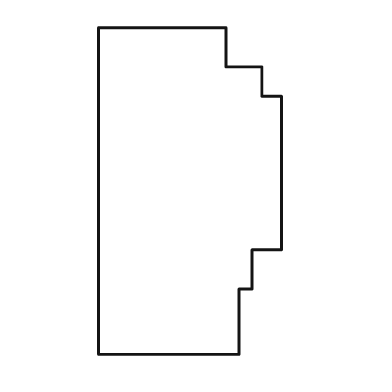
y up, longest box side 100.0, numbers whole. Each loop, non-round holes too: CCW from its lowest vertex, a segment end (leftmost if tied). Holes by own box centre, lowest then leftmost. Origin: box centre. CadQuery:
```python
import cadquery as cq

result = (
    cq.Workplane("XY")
    .moveTo(-28.0, -50.0)
    .lineTo(15.0, -50.0)
    .lineTo(15.0, -30.0)
    .lineTo(19.0, -30.0)
    .lineTo(19.0, -18.0)
    .lineTo(28.0, -18.0)
    .lineTo(28.0, 29.0)
    .lineTo(22.0, 29.0)
    .lineTo(22.0, 38.0)
    .lineTo(11.0, 38.0)
    .lineTo(11.0, 50.0)
    .lineTo(-28.0, 50.0)
    .close()
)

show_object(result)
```